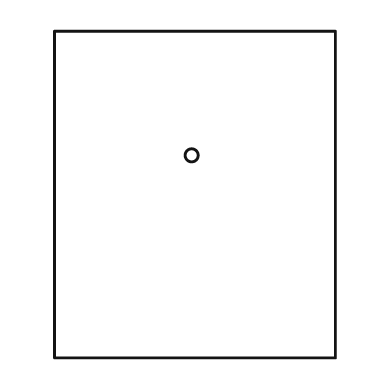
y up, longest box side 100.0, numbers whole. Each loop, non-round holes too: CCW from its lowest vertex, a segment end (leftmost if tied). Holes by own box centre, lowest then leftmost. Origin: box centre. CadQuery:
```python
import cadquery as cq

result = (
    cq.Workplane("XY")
    .moveTo(-43.0, -50.0)
    .lineTo(43.0, -50.0)
    .lineTo(43.0, 50.0)
    .lineTo(-43.0, 50.0)
    .close()
    .moveTo(-1.0, 12.0)
    .circle(2.0)
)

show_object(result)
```